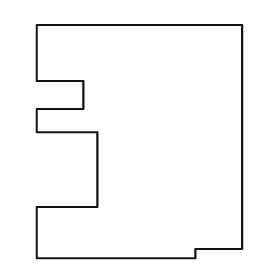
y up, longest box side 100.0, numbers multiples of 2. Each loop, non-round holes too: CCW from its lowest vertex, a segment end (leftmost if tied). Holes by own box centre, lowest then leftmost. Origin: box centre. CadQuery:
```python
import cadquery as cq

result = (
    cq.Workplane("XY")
    .moveTo(-44.0, -50.0)
    .lineTo(24.0, -50.0)
    .lineTo(24.0, -46.0)
    .lineTo(44.0, -46.0)
    .lineTo(44.0, 50.0)
    .lineTo(-44.0, 50.0)
    .lineTo(-44.0, 26.0)
    .lineTo(-24.0, 26.0)
    .lineTo(-24.0, 14.0)
    .lineTo(-44.0, 14.0)
    .lineTo(-44.0, 4.0)
    .lineTo(-18.0, 4.0)
    .lineTo(-18.0, -28.0)
    .lineTo(-44.0, -28.0)
    .close()
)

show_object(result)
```